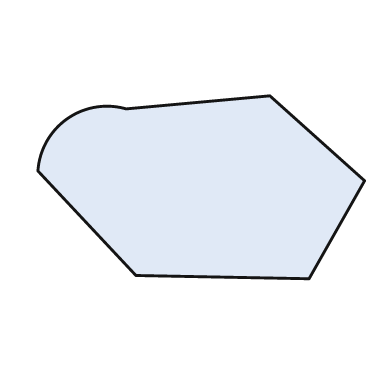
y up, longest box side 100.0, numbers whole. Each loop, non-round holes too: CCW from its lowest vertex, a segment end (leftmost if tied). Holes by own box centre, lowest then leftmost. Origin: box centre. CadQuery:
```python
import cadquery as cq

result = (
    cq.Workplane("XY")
    .moveTo(33.0, -28.0)
    .lineTo(50.0, 2.0)
    .lineTo(21.0, 28.0)
    .lineTo(-23.0, 24.0)
    .threePointArc((-41.0, 21.0), (-50.0, 5.0))
    .lineTo(-20.0, -27.0)
    .close()
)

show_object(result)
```